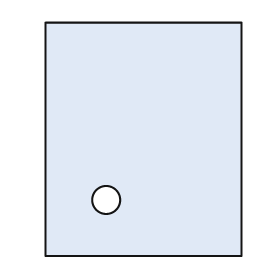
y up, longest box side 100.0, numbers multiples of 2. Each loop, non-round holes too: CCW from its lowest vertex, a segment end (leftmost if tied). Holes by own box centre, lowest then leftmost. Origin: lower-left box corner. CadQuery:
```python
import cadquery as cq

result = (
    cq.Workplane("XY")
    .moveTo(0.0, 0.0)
    .lineTo(84.0, 0.0)
    .lineTo(84.0, 100.0)
    .lineTo(0.0, 100.0)
    .close()
    .moveTo(26.0, 24.0)
    .circle(6.0)
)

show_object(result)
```